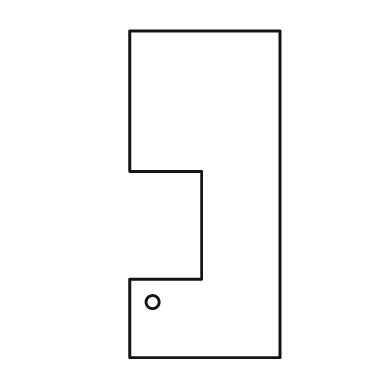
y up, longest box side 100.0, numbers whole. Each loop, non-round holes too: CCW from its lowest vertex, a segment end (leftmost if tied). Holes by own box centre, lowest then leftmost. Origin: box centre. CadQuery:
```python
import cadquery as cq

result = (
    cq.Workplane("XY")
    .moveTo(-23.0, -50.0)
    .lineTo(23.0, -50.0)
    .lineTo(23.0, 50.0)
    .lineTo(-23.0, 50.0)
    .lineTo(-23.0, 7.0)
    .lineTo(-1.0, 7.0)
    .lineTo(-1.0, -26.0)
    .lineTo(-23.0, -26.0)
    .close()
    .moveTo(-16.0, -33.0)
    .circle(2.0)
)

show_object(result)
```